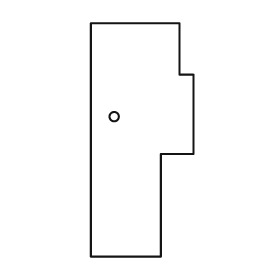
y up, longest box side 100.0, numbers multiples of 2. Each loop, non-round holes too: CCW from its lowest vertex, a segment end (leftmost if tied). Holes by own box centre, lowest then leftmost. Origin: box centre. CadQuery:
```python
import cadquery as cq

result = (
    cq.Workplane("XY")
    .moveTo(-22.0, -50.0)
    .lineTo(8.0, -50.0)
    .lineTo(8.0, -6.0)
    .lineTo(22.0, -6.0)
    .lineTo(22.0, 28.0)
    .lineTo(16.0, 28.0)
    .lineTo(16.0, 50.0)
    .lineTo(-22.0, 50.0)
    .close()
    .moveTo(-12.0, 10.0)
    .circle(2.0)
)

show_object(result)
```